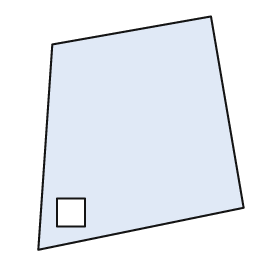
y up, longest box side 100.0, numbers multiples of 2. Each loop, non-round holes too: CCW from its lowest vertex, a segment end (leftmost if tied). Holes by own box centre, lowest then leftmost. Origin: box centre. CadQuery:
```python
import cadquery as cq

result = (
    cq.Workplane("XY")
    .moveTo(-44.0, -50.0)
    .lineTo(44.0, -32.0)
    .lineTo(30.0, 50.0)
    .lineTo(-38.0, 38.0)
    .close()
    .moveTo(-36.0, -40.0)
    .lineTo(-24.0, -40.0)
    .lineTo(-24.0, -28.0)
    .lineTo(-36.0, -28.0)
    .close()
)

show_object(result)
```